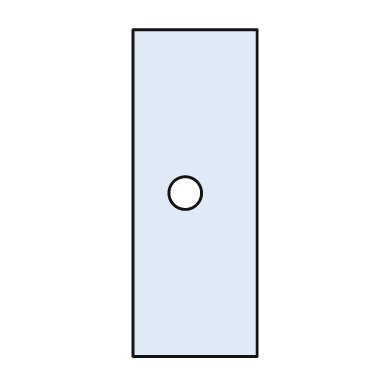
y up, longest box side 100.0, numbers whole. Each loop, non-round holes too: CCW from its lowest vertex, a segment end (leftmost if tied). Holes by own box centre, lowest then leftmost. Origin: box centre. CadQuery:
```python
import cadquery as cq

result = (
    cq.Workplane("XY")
    .moveTo(-19.0, -50.0)
    .lineTo(19.0, -50.0)
    .lineTo(19.0, 50.0)
    .lineTo(-19.0, 50.0)
    .close()
    .moveTo(-3.0, 0.0)
    .circle(5.0)
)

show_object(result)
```